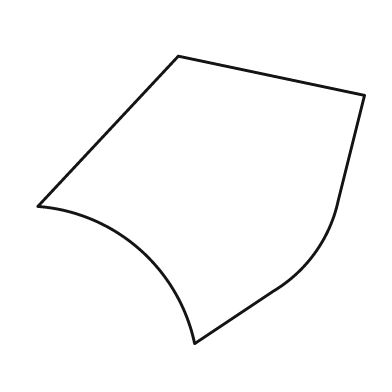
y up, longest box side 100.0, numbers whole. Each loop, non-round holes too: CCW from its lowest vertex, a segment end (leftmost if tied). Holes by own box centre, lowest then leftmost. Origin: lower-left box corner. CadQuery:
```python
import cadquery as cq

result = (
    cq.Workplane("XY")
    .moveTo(48.0, 0.0)
    .lineTo(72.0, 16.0)
    .threePointArc((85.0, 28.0), (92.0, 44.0))
    .lineTo(100.0, 76.0)
    .lineTo(43.0, 88.0)
    .lineTo(0.0, 42.0)
    .threePointArc((31.0, 29.0), (48.0, 0.0))
    .close()
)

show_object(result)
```